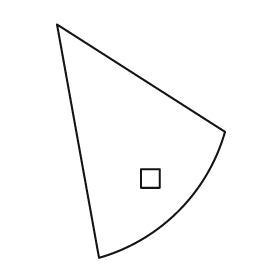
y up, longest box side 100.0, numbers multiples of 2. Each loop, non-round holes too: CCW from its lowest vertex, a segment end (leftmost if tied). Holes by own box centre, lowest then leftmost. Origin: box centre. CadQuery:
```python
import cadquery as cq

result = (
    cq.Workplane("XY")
    .moveTo(-18.0, -50.0)
    .threePointArc((16.0, -30.0), (36.0, 4.0))
    .lineTo(-36.0, 50.0)
    .close()
    .moveTo(0.0, -20.0)
    .lineTo(8.0, -20.0)
    .lineTo(8.0, -12.0)
    .lineTo(0.0, -12.0)
    .close()
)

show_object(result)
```